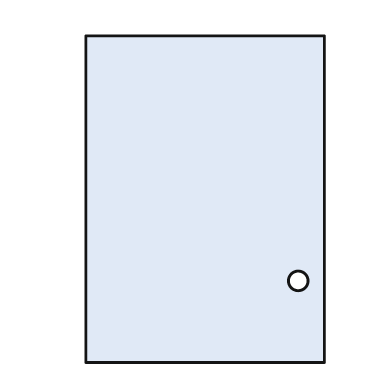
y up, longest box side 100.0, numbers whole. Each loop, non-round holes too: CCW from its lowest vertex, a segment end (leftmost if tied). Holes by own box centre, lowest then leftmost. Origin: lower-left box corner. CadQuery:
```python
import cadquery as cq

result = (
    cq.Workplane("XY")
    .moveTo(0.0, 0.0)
    .lineTo(73.0, 0.0)
    .lineTo(73.0, 100.0)
    .lineTo(0.0, 100.0)
    .close()
    .moveTo(65.0, 25.0)
    .circle(3.0)
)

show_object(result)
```